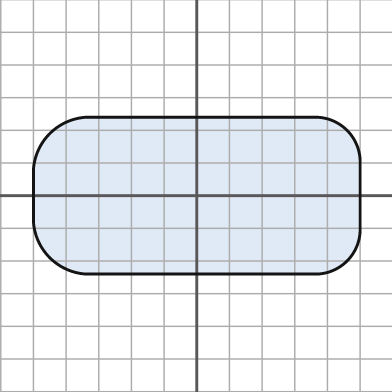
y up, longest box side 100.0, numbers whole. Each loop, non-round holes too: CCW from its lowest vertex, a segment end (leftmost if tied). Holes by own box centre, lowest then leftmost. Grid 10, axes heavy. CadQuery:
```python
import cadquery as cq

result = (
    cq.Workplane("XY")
    .moveTo(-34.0, -24.0)
    .lineTo(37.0, -24.0)
    .threePointArc((46.0, -20.0), (50.0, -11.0))
    .lineTo(50.0, 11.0)
    .threePointArc((46.0, 20.0), (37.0, 24.0))
    .lineTo(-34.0, 24.0)
    .threePointArc((-45.0, 19.0), (-50.0, 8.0))
    .lineTo(-50.0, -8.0)
    .threePointArc((-45.0, -19.0), (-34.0, -24.0))
    .close()
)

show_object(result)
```